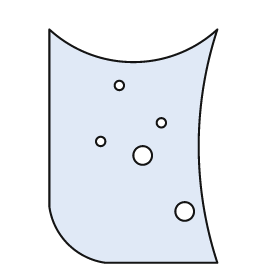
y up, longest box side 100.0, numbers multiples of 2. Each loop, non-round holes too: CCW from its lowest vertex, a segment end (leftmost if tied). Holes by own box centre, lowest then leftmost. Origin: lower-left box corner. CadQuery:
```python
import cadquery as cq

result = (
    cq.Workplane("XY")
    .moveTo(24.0, 0.0)
    .lineTo(72.0, 0.0)
    .threePointArc((64.0, 50.0), (72.0, 100.0))
    .threePointArc((36.0, 86.0), (0.0, 100.0))
    .lineTo(0.0, 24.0)
    .threePointArc((8.0, 8.0), (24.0, 0.0))
    .close()
    .moveTo(58.0, 22.0)
    .circle(4.0)
    .moveTo(40.0, 46.0)
    .circle(4.0)
    .moveTo(22.0, 52.0)
    .circle(2.0)
    .moveTo(48.0, 60.0)
    .circle(2.0)
    .moveTo(30.0, 76.0)
    .circle(2.0)
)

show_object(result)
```